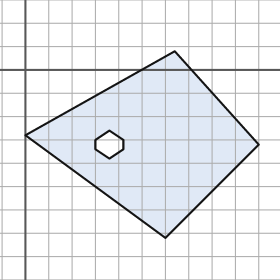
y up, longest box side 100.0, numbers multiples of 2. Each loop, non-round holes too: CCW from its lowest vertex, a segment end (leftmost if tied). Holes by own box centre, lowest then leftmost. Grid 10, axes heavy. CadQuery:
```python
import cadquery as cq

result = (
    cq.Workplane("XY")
    .moveTo(60.0, -72.0)
    .lineTo(100.0, -32.0)
    .lineTo(64.0, 8.0)
    .lineTo(0.0, -28.0)
    .close()
    .moveTo(36.0, -38.0)
    .lineTo(42.0, -34.0)
    .lineTo(42.0, -30.0)
    .lineTo(36.0, -26.0)
    .lineTo(30.0, -30.0)
    .lineTo(30.0, -34.0)
    .close()
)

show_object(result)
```